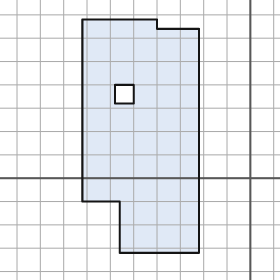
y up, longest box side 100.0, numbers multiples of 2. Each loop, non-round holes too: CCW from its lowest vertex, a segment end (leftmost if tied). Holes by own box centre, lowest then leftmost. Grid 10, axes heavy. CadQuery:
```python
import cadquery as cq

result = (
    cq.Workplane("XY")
    .moveTo(-56.0, -32.0)
    .lineTo(-22.0, -32.0)
    .lineTo(-22.0, 64.0)
    .lineTo(-40.0, 64.0)
    .lineTo(-40.0, 68.0)
    .lineTo(-72.0, 68.0)
    .lineTo(-72.0, -10.0)
    .lineTo(-56.0, -10.0)
    .close()
    .moveTo(-58.0, 32.0)
    .lineTo(-50.0, 32.0)
    .lineTo(-50.0, 40.0)
    .lineTo(-58.0, 40.0)
    .close()
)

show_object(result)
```